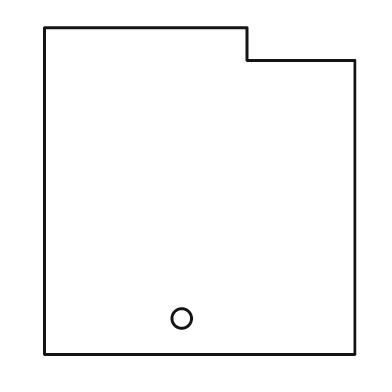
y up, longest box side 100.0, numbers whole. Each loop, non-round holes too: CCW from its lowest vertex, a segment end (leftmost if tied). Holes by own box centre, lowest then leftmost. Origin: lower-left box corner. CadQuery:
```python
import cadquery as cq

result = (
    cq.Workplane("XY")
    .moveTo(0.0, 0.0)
    .lineTo(95.0, 0.0)
    .lineTo(95.0, 90.0)
    .lineTo(62.0, 90.0)
    .lineTo(62.0, 100.0)
    .lineTo(0.0, 100.0)
    .close()
    .moveTo(42.0, 11.0)
    .circle(3.0)
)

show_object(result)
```